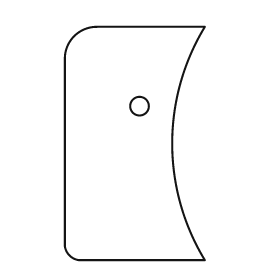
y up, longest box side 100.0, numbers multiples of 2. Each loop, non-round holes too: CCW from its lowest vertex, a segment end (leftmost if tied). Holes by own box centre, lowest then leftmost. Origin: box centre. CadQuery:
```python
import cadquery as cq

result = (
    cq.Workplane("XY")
    .moveTo(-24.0, -50.0)
    .lineTo(30.0, -50.0)
    .threePointArc((16.0, 0.0), (30.0, 50.0))
    .lineTo(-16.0, 50.0)
    .threePointArc((-26.0, 46.0), (-30.0, 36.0))
    .lineTo(-30.0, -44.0)
    .threePointArc((-28.0, -48.0), (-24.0, -50.0))
    .close()
    .moveTo(2.0, 16.0)
    .circle(4.0)
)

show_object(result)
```